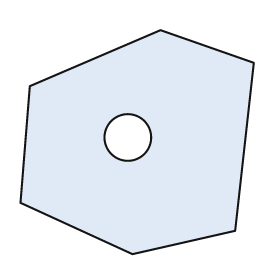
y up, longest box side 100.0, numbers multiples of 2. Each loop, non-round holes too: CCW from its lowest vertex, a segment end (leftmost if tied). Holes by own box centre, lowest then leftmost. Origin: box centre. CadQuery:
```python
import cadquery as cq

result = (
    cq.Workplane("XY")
    .moveTo(-2.0, -48.0)
    .lineTo(42.0, -38.0)
    .lineTo(50.0, 34.0)
    .lineTo(10.0, 48.0)
    .lineTo(-46.0, 24.0)
    .lineTo(-50.0, -26.0)
    .close()
    .moveTo(-4.0, 2.0)
    .circle(10.0)
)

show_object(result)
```